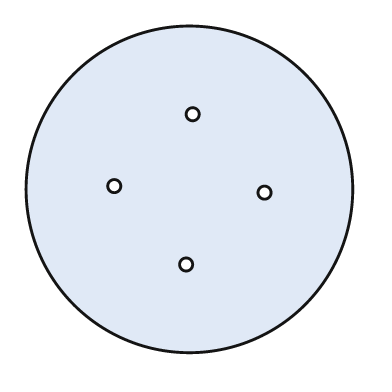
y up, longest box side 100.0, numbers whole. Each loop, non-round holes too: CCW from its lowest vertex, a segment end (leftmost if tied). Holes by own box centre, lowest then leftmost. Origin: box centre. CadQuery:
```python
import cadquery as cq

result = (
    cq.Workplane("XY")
    .moveTo(0.0, 0.0)
    .circle(50.0)
    .moveTo(-1.0, -23.0)
    .circle(2.0)
    .moveTo(23.0, -1.0)
    .circle(2.0)
    .moveTo(-23.0, 1.0)
    .circle(2.0)
    .moveTo(1.0, 23.0)
    .circle(2.0)
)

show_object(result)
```